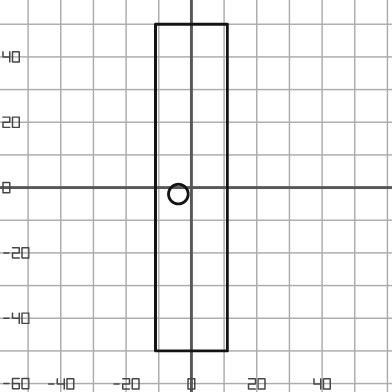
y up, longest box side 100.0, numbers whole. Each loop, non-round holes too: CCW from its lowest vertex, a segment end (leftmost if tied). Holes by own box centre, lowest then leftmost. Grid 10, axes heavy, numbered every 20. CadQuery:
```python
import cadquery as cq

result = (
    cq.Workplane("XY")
    .moveTo(-11.0, -50.0)
    .lineTo(11.0, -50.0)
    .lineTo(11.0, 50.0)
    .lineTo(-11.0, 50.0)
    .close()
    .moveTo(-4.0, -2.0)
    .circle(3.0)
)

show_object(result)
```